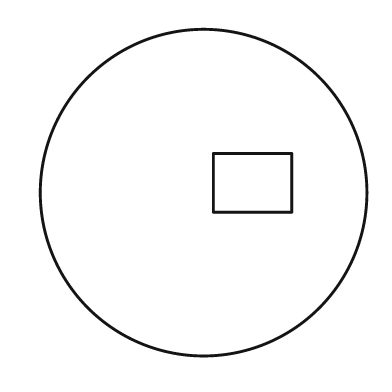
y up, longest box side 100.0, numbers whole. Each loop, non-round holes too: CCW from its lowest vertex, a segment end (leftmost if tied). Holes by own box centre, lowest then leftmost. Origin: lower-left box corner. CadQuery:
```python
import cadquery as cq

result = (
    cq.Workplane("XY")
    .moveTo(50.0, 50.0)
    .circle(50.0)
    .moveTo(53.0, 44.0)
    .lineTo(77.0, 44.0)
    .lineTo(77.0, 62.0)
    .lineTo(53.0, 62.0)
    .close()
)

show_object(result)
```